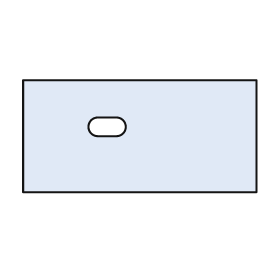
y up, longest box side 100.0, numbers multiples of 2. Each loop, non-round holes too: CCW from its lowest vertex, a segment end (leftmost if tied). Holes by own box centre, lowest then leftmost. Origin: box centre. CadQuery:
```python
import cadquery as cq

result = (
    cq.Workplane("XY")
    .moveTo(-50.0, -24.0)
    .lineTo(50.0, -24.0)
    .lineTo(50.0, 24.0)
    .lineTo(-50.0, 24.0)
    .close()
    .moveTo(-18.0, 0.0)
    .lineTo(-10.0, 0.0)
    .threePointArc((-6.0, 4.0), (-10.0, 8.0))
    .lineTo(-18.0, 8.0)
    .threePointArc((-22.0, 4.0), (-18.0, 0.0))
    .close()
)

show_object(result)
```